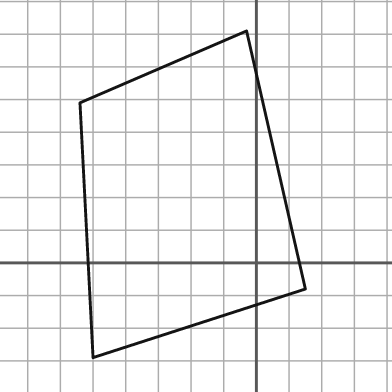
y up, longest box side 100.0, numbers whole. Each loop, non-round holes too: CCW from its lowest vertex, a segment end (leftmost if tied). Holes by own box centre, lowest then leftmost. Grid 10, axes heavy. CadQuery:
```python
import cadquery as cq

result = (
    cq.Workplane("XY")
    .moveTo(-50.0, -29.0)
    .lineTo(15.0, -8.0)
    .lineTo(-3.0, 71.0)
    .lineTo(-54.0, 49.0)
    .close()
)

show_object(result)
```